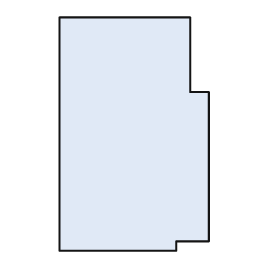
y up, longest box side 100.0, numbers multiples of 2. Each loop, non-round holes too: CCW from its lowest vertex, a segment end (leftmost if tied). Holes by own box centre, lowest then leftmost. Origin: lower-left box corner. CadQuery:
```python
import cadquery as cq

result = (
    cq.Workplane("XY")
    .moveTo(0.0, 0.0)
    .lineTo(50.0, 0.0)
    .lineTo(50.0, 4.0)
    .lineTo(64.0, 4.0)
    .lineTo(64.0, 68.0)
    .lineTo(56.0, 68.0)
    .lineTo(56.0, 100.0)
    .lineTo(0.0, 100.0)
    .close()
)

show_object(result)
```